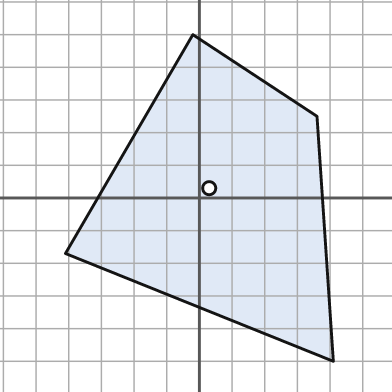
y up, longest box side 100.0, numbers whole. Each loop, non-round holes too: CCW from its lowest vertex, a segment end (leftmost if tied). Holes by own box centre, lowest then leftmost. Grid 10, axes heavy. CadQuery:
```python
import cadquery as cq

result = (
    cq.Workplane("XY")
    .moveTo(41.0, -50.0)
    .lineTo(36.0, 25.0)
    .lineTo(-2.0, 50.0)
    .lineTo(-41.0, -17.0)
    .close()
    .moveTo(3.0, 3.0)
    .circle(2.0)
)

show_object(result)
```